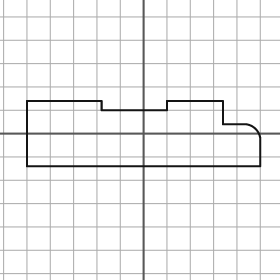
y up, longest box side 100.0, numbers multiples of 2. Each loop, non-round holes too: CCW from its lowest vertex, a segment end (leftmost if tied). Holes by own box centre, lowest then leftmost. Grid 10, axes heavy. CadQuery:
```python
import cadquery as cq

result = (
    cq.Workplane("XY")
    .moveTo(-50.0, -14.0)
    .lineTo(50.0, -14.0)
    .lineTo(50.0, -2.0)
    .threePointArc((48.0, 2.0), (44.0, 4.0))
    .lineTo(34.0, 4.0)
    .lineTo(34.0, 14.0)
    .lineTo(10.0, 14.0)
    .lineTo(10.0, 10.0)
    .lineTo(-18.0, 10.0)
    .lineTo(-18.0, 14.0)
    .lineTo(-50.0, 14.0)
    .close()
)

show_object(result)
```